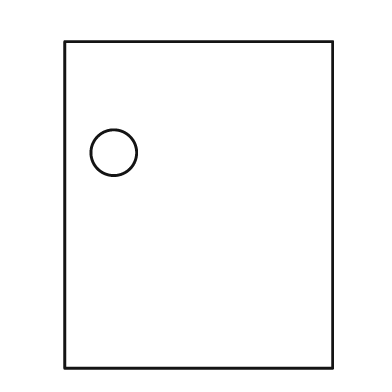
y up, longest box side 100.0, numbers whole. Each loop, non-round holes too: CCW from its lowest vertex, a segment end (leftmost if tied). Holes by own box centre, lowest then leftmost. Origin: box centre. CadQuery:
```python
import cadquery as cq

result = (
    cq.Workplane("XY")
    .moveTo(-41.0, -50.0)
    .lineTo(41.0, -50.0)
    .lineTo(41.0, 50.0)
    .lineTo(-41.0, 50.0)
    .close()
    .moveTo(-26.0, 16.0)
    .circle(7.0)
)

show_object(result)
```